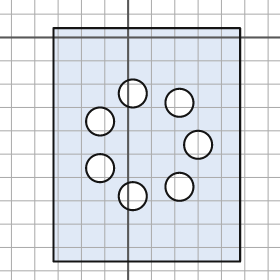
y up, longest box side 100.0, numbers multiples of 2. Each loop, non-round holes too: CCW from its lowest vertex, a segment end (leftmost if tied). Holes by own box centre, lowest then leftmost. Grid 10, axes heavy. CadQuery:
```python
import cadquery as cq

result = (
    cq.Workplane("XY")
    .moveTo(-32.0, -96.0)
    .lineTo(48.0, -96.0)
    .lineTo(48.0, 4.0)
    .lineTo(-32.0, 4.0)
    .close()
    .moveTo(2.0, -68.0)
    .circle(6.0)
    .moveTo(22.0, -64.0)
    .circle(6.0)
    .moveTo(-12.0, -56.0)
    .circle(6.0)
    .moveTo(30.0, -46.0)
    .circle(6.0)
    .moveTo(-12.0, -36.0)
    .circle(6.0)
    .moveTo(22.0, -28.0)
    .circle(6.0)
    .moveTo(2.0, -24.0)
    .circle(6.0)
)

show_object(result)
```